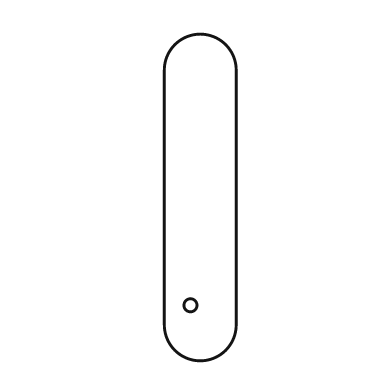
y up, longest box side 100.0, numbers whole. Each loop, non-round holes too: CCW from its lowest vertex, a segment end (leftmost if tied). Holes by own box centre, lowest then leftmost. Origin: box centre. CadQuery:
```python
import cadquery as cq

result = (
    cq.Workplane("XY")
    .moveTo(-11.0, -39.0)
    .threePointArc((0.0, -50.0), (11.0, -39.0))
    .lineTo(11.0, 39.0)
    .threePointArc((0.0, 50.0), (-11.0, 39.0))
    .close()
    .moveTo(-3.0, -33.0)
    .circle(2.0)
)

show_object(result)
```